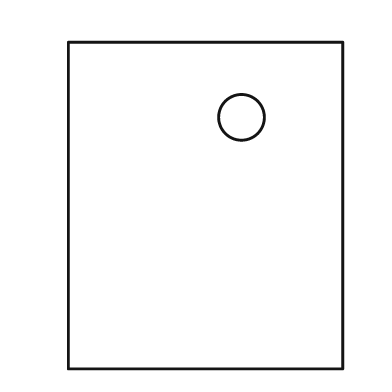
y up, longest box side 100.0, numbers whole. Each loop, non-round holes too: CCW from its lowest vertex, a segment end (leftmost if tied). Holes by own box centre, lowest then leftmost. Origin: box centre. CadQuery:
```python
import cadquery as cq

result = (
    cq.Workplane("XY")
    .moveTo(-42.0, -50.0)
    .lineTo(42.0, -50.0)
    .lineTo(42.0, 50.0)
    .lineTo(-42.0, 50.0)
    .close()
    .moveTo(11.0, 27.0)
    .circle(7.0)
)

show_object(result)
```